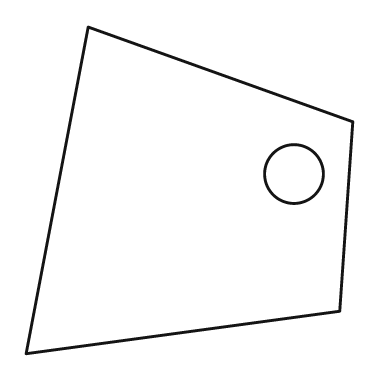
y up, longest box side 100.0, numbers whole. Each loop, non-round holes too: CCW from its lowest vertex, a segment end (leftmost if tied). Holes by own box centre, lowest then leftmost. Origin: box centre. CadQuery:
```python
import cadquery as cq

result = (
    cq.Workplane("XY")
    .moveTo(-50.0, -50.0)
    .lineTo(46.0, -37.0)
    .lineTo(50.0, 21.0)
    .lineTo(-31.0, 50.0)
    .close()
    .moveTo(32.0, 5.0)
    .circle(9.0)
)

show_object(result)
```